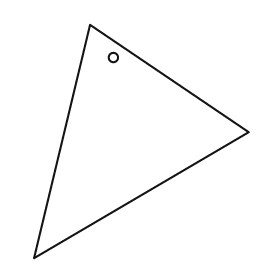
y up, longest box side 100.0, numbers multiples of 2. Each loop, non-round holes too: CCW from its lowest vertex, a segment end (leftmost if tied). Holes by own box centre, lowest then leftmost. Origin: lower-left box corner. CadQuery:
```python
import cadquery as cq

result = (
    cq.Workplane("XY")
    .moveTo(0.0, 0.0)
    .lineTo(92.0, 54.0)
    .lineTo(24.0, 100.0)
    .close()
    .moveTo(34.0, 86.0)
    .circle(2.0)
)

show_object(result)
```